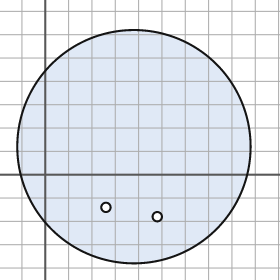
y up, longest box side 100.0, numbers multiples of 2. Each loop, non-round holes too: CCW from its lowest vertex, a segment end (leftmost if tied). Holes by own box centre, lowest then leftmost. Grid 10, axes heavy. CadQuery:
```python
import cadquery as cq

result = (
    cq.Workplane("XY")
    .moveTo(38.0, 12.0)
    .circle(50.0)
    .moveTo(48.0, -18.0)
    .circle(2.0)
    .moveTo(26.0, -14.0)
    .circle(2.0)
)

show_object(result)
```